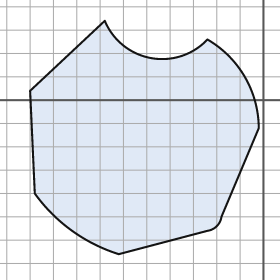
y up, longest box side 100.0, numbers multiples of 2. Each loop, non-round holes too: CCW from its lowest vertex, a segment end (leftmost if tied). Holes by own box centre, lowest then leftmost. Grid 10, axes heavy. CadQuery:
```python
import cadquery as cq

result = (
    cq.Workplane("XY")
    .moveTo(-62.0, -66.0)
    .lineTo(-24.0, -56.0)
    .threePointArc((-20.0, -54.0), (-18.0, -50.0))
    .lineTo(-2.0, -12.0)
    .threePointArc((-8.0, 10.0), (-24.0, 26.0))
    .threePointArc((-48.0, 18.0), (-68.0, 34.0))
    .lineTo(-100.0, 4.0)
    .lineTo(-98.0, -40.0)
    .threePointArc((-82.0, -56.0), (-62.0, -66.0))
    .close()
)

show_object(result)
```